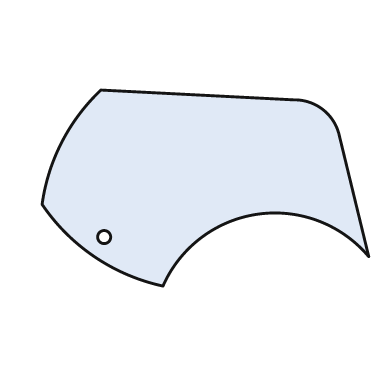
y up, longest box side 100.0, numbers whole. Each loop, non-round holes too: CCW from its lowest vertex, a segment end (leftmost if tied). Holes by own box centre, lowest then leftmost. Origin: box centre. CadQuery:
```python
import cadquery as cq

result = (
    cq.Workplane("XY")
    .moveTo(-13.0, -30.0)
    .threePointArc((16.0, -8.0), (50.0, -21.0))
    .lineTo(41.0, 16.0)
    .threePointArc((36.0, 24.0), (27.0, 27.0))
    .lineTo(-32.0, 30.0)
    .threePointArc((-44.0, 14.0), (-50.0, -5.0))
    .threePointArc((-34.0, -21.0), (-13.0, -30.0))
    .close()
    .moveTo(-31.0, -15.0)
    .circle(2.0)
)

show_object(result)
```